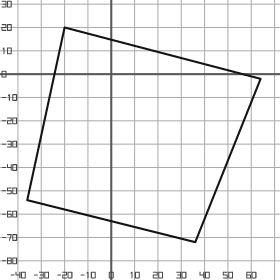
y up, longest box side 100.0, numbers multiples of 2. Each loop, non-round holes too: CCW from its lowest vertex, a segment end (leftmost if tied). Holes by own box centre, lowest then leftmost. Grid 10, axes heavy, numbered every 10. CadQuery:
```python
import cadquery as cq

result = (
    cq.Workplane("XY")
    .moveTo(36.0, -72.0)
    .lineTo(64.0, -2.0)
    .lineTo(-20.0, 20.0)
    .lineTo(-36.0, -54.0)
    .close()
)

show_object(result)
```